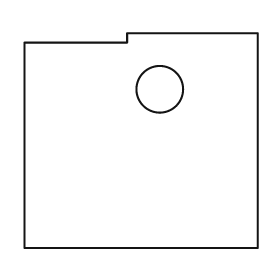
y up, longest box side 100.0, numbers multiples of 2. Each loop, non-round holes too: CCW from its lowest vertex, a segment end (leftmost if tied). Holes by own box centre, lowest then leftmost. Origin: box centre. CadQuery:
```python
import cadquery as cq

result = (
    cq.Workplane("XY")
    .moveTo(-50.0, -46.0)
    .lineTo(50.0, -46.0)
    .lineTo(50.0, 46.0)
    .lineTo(-6.0, 46.0)
    .lineTo(-6.0, 42.0)
    .lineTo(-50.0, 42.0)
    .close()
    .moveTo(8.0, 22.0)
    .circle(10.0)
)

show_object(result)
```